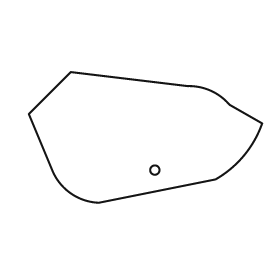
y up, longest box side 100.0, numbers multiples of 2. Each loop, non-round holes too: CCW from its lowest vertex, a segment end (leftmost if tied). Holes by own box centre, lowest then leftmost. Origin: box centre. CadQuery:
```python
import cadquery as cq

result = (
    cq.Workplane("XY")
    .moveTo(-20.0, -28.0)
    .lineTo(30.0, -18.0)
    .threePointArc((42.0, -8.0), (50.0, 6.0))
    .lineTo(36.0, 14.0)
    .threePointArc((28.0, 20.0), (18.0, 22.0))
    .lineTo(-32.0, 28.0)
    .lineTo(-50.0, 10.0)
    .lineTo(-40.0, -14.0)
    .threePointArc((-32.0, -24.0), (-20.0, -28.0))
    .close()
    .moveTo(4.0, -14.0)
    .circle(2.0)
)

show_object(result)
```